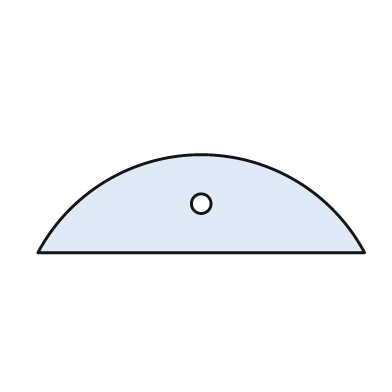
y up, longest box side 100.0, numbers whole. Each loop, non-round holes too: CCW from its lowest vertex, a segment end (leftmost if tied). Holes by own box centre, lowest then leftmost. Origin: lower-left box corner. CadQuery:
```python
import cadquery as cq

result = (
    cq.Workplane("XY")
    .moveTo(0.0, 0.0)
    .lineTo(100.0, 0.0)
    .threePointArc((50.0, 30.0), (0.0, 0.0))
    .close()
    .moveTo(50.0, 15.0)
    .circle(3.0)
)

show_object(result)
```